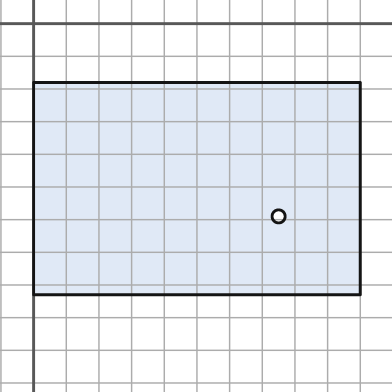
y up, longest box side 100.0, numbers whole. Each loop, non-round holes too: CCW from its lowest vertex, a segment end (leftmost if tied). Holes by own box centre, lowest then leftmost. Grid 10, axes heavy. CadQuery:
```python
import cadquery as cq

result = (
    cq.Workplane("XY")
    .moveTo(0.0, -83.0)
    .lineTo(100.0, -83.0)
    .lineTo(100.0, -18.0)
    .lineTo(0.0, -18.0)
    .close()
    .moveTo(75.0, -59.0)
    .circle(2.0)
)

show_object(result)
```